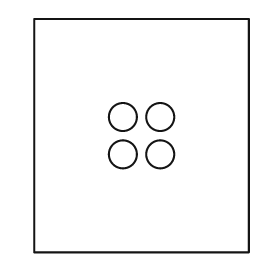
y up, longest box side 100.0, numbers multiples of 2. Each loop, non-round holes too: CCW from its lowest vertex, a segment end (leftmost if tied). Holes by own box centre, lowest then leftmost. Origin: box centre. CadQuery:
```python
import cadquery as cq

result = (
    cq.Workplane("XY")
    .moveTo(-46.0, -50.0)
    .lineTo(46.0, -50.0)
    .lineTo(46.0, 50.0)
    .lineTo(-46.0, 50.0)
    .close()
    .moveTo(-8.0, -8.0)
    .circle(6.0)
    .moveTo(8.0, -8.0)
    .circle(6.0)
    .moveTo(-8.0, 8.0)
    .circle(6.0)
    .moveTo(8.0, 8.0)
    .circle(6.0)
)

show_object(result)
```